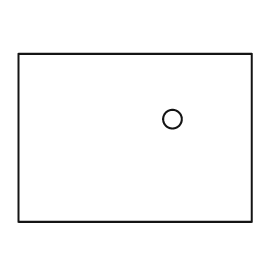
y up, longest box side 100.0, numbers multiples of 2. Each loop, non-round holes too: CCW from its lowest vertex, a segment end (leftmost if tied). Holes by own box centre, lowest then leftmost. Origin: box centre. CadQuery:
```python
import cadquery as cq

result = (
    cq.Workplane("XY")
    .moveTo(-50.0, -36.0)
    .lineTo(50.0, -36.0)
    .lineTo(50.0, 36.0)
    .lineTo(-50.0, 36.0)
    .close()
    .moveTo(16.0, 8.0)
    .circle(4.0)
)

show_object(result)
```